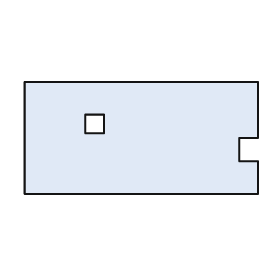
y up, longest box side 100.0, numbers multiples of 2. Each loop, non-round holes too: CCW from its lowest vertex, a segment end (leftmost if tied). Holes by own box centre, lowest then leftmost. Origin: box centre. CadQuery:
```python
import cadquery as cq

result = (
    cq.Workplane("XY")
    .moveTo(-50.0, -24.0)
    .lineTo(50.0, -24.0)
    .lineTo(50.0, -10.0)
    .lineTo(42.0, -10.0)
    .lineTo(42.0, 0.0)
    .lineTo(50.0, 0.0)
    .lineTo(50.0, 24.0)
    .lineTo(-50.0, 24.0)
    .close()
    .moveTo(-24.0, 2.0)
    .lineTo(-16.0, 2.0)
    .lineTo(-16.0, 10.0)
    .lineTo(-24.0, 10.0)
    .close()
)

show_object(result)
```